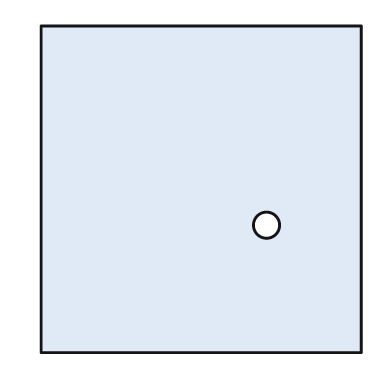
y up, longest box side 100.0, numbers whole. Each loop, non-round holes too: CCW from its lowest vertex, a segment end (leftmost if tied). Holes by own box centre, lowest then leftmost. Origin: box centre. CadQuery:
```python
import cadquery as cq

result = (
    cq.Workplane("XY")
    .moveTo(-49.0, -50.0)
    .lineTo(49.0, -50.0)
    .lineTo(49.0, 50.0)
    .lineTo(-49.0, 50.0)
    .close()
    .moveTo(20.0, -11.0)
    .circle(4.0)
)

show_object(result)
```